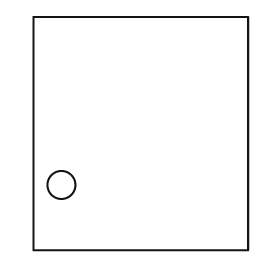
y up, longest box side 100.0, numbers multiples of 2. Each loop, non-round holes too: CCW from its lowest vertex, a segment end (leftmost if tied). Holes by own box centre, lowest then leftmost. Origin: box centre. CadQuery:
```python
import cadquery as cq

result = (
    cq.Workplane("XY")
    .moveTo(-46.0, -50.0)
    .lineTo(46.0, -50.0)
    .lineTo(46.0, 50.0)
    .lineTo(-46.0, 50.0)
    .close()
    .moveTo(-34.0, -22.0)
    .circle(6.0)
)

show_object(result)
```